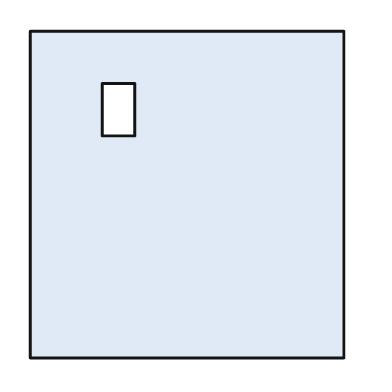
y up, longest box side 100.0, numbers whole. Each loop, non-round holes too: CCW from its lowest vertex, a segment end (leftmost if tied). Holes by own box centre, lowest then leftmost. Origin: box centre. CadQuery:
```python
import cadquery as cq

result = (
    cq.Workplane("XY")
    .moveTo(-48.0, -50.0)
    .lineTo(48.0, -50.0)
    .lineTo(48.0, 50.0)
    .lineTo(-48.0, 50.0)
    .close()
    .moveTo(-26.0, 18.0)
    .lineTo(-16.0, 18.0)
    .lineTo(-16.0, 34.0)
    .lineTo(-26.0, 34.0)
    .close()
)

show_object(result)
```